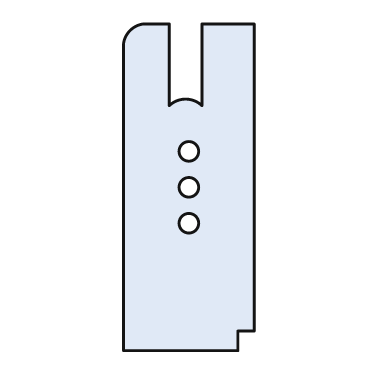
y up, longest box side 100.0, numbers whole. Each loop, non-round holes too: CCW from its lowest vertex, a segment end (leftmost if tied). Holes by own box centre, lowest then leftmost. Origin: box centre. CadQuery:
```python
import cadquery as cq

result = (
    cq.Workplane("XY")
    .moveTo(-20.0, -50.0)
    .lineTo(15.0, -50.0)
    .lineTo(15.0, -44.0)
    .lineTo(20.0, -44.0)
    .lineTo(20.0, 50.0)
    .lineTo(4.0, 50.0)
    .lineTo(4.0, 25.0)
    .threePointArc((-1.0, 27.0), (-6.0, 25.0))
    .lineTo(-6.0, 50.0)
    .lineTo(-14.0, 50.0)
    .threePointArc((-18.0, 48.0), (-20.0, 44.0))
    .close()
    .moveTo(0.0, -11.0)
    .circle(3.0)
    .moveTo(0.0, 0.0)
    .circle(3.0)
    .moveTo(0.0, 11.0)
    .circle(3.0)
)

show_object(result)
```